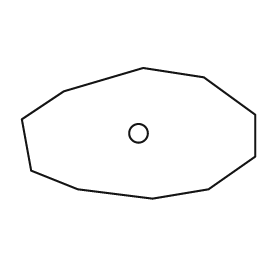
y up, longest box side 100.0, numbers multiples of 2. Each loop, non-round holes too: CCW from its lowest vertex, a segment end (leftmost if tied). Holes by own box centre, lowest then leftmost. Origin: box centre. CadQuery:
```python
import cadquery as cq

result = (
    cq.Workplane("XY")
    .moveTo(6.0, -28.0)
    .lineTo(30.0, -24.0)
    .lineTo(50.0, -10.0)
    .lineTo(50.0, 8.0)
    .lineTo(28.0, 24.0)
    .lineTo(2.0, 28.0)
    .lineTo(-32.0, 18.0)
    .lineTo(-50.0, 6.0)
    .lineTo(-46.0, -16.0)
    .lineTo(-26.0, -24.0)
    .close()
    .moveTo(0.0, 0.0)
    .circle(4.0)
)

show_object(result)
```